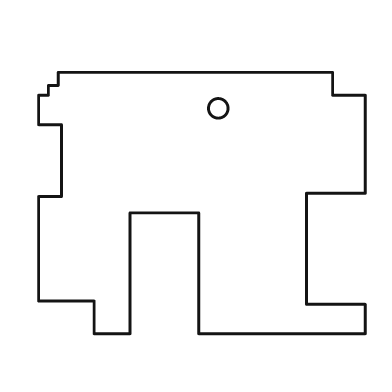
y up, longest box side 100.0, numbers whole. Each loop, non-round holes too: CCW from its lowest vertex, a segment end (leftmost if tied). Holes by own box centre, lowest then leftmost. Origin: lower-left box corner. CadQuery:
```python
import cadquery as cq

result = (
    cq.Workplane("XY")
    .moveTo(17.0, 0.0)
    .lineTo(28.0, 0.0)
    .lineTo(28.0, 37.0)
    .lineTo(49.0, 37.0)
    .lineTo(49.0, 0.0)
    .lineTo(100.0, 0.0)
    .lineTo(100.0, 9.0)
    .lineTo(82.0, 9.0)
    .lineTo(82.0, 43.0)
    .lineTo(100.0, 43.0)
    .lineTo(100.0, 73.0)
    .lineTo(90.0, 73.0)
    .lineTo(90.0, 80.0)
    .lineTo(6.0, 80.0)
    .lineTo(6.0, 76.0)
    .lineTo(3.0, 76.0)
    .lineTo(3.0, 73.0)
    .lineTo(0.0, 73.0)
    .lineTo(0.0, 64.0)
    .lineTo(7.0, 64.0)
    .lineTo(7.0, 42.0)
    .lineTo(0.0, 42.0)
    .lineTo(0.0, 10.0)
    .lineTo(17.0, 10.0)
    .close()
    .moveTo(55.0, 69.0)
    .circle(3.0)
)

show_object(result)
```